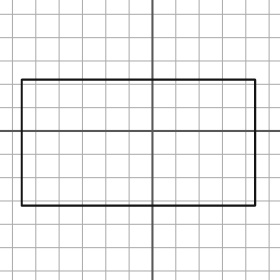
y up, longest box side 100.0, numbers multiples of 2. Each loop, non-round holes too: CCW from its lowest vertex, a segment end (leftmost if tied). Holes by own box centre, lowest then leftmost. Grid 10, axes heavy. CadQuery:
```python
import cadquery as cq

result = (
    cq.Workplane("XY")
    .moveTo(-56.0, -32.0)
    .lineTo(44.0, -32.0)
    .lineTo(44.0, 22.0)
    .lineTo(-56.0, 22.0)
    .close()
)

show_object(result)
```